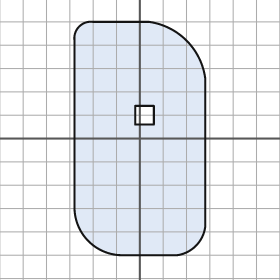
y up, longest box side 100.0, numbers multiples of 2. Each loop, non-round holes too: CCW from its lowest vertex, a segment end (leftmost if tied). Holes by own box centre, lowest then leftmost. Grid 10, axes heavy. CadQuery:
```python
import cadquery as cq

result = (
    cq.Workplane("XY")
    .moveTo(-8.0, -50.0)
    .lineTo(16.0, -50.0)
    .threePointArc((24.0, -46.0), (28.0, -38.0))
    .lineTo(28.0, 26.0)
    .threePointArc((20.0, 42.0), (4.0, 50.0))
    .lineTo(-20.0, 50.0)
    .threePointArc((-26.0, 48.0), (-28.0, 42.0))
    .lineTo(-28.0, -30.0)
    .threePointArc((-22.0, -44.0), (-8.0, -50.0))
    .close()
    .moveTo(-2.0, 6.0)
    .lineTo(6.0, 6.0)
    .lineTo(6.0, 14.0)
    .lineTo(-2.0, 14.0)
    .close()
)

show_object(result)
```